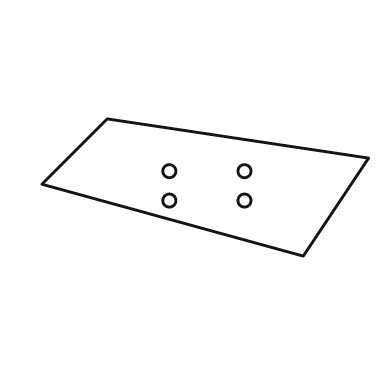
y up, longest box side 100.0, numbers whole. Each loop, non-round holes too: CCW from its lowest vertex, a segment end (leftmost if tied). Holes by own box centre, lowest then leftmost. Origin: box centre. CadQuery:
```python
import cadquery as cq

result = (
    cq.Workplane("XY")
    .moveTo(30.0, -21.0)
    .lineTo(50.0, 9.0)
    .lineTo(-30.0, 21.0)
    .lineTo(-50.0, 1.0)
    .close()
    .moveTo(-11.0, -4.0)
    .circle(2.0)
    .moveTo(12.0, -4.0)
    .circle(2.0)
    .moveTo(-11.0, 5.0)
    .circle(2.0)
    .moveTo(12.0, 5.0)
    .circle(2.0)
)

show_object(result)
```